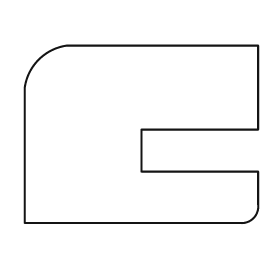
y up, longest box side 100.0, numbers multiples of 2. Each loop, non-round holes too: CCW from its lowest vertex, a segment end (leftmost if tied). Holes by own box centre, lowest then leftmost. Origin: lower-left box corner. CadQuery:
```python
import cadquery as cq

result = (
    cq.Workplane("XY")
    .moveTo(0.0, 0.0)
    .lineTo(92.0, 0.0)
    .threePointArc((98.0, 2.0), (100.0, 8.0))
    .lineTo(100.0, 22.0)
    .lineTo(50.0, 22.0)
    .lineTo(50.0, 40.0)
    .lineTo(100.0, 40.0)
    .lineTo(100.0, 76.0)
    .lineTo(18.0, 76.0)
    .threePointArc((6.0, 70.0), (0.0, 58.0))
    .close()
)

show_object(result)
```